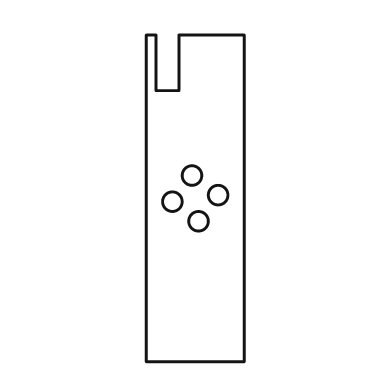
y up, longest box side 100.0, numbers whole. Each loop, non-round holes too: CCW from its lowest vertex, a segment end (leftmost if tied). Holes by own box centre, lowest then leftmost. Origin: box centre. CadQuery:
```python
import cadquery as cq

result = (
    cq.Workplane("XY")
    .moveTo(-15.0, -50.0)
    .lineTo(15.0, -50.0)
    .lineTo(15.0, 50.0)
    .lineTo(-5.0, 50.0)
    .lineTo(-5.0, 33.0)
    .lineTo(-12.0, 33.0)
    .lineTo(-12.0, 50.0)
    .lineTo(-15.0, 50.0)
    .close()
    .moveTo(1.0, -7.0)
    .circle(3.0)
    .moveTo(-7.0, -1.0)
    .circle(3.0)
    .moveTo(7.0, 1.0)
    .circle(3.0)
    .moveTo(-1.0, 7.0)
    .circle(3.0)
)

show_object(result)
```